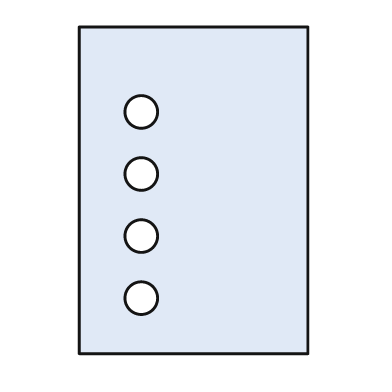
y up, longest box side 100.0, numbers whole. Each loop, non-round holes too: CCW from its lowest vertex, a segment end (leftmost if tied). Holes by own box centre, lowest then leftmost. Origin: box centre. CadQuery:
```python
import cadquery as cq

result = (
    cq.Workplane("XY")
    .moveTo(-35.0, -50.0)
    .lineTo(35.0, -50.0)
    .lineTo(35.0, 50.0)
    .lineTo(-35.0, 50.0)
    .close()
    .moveTo(-16.0, -33.0)
    .circle(5.0)
    .moveTo(-16.0, -14.0)
    .circle(5.0)
    .moveTo(-16.0, 5.0)
    .circle(5.0)
    .moveTo(-16.0, 24.0)
    .circle(5.0)
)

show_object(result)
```